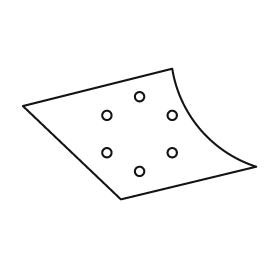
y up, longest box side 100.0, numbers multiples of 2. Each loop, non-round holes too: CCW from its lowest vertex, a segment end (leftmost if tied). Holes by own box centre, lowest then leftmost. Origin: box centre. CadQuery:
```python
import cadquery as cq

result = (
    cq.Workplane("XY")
    .moveTo(-8.0, -28.0)
    .lineTo(50.0, -14.0)
    .threePointArc((26.0, 2.0), (14.0, 28.0))
    .lineTo(-50.0, 12.0)
    .close()
    .moveTo(0.0, -16.0)
    .circle(2.0)
    .moveTo(-14.0, -8.0)
    .circle(2.0)
    .moveTo(14.0, -8.0)
    .circle(2.0)
    .moveTo(-14.0, 8.0)
    .circle(2.0)
    .moveTo(14.0, 8.0)
    .circle(2.0)
    .moveTo(0.0, 16.0)
    .circle(2.0)
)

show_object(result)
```